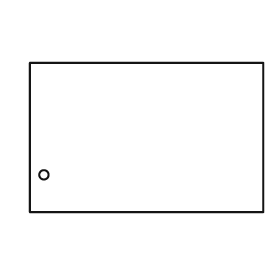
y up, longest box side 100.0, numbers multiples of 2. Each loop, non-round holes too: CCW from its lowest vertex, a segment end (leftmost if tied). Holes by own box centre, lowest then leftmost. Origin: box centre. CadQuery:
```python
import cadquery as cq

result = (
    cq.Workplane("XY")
    .moveTo(-50.0, -32.0)
    .lineTo(50.0, -32.0)
    .lineTo(50.0, 32.0)
    .lineTo(-50.0, 32.0)
    .close()
    .moveTo(-44.0, -16.0)
    .circle(2.0)
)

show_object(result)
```